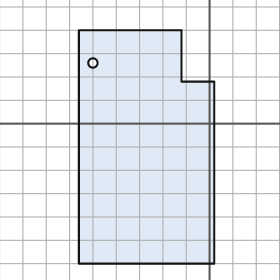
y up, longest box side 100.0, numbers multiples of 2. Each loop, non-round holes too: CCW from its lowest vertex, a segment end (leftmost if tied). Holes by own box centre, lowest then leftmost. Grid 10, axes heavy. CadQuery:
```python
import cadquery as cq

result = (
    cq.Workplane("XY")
    .moveTo(-56.0, -60.0)
    .lineTo(2.0, -60.0)
    .lineTo(2.0, 18.0)
    .lineTo(-12.0, 18.0)
    .lineTo(-12.0, 40.0)
    .lineTo(-56.0, 40.0)
    .close()
    .moveTo(-50.0, 26.0)
    .circle(2.0)
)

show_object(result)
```